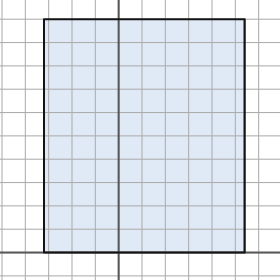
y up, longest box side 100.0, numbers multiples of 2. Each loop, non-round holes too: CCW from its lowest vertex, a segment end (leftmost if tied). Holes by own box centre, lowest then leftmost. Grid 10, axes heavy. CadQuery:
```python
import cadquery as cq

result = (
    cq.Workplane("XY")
    .moveTo(-32.0, 0.0)
    .lineTo(54.0, 0.0)
    .lineTo(54.0, 100.0)
    .lineTo(-32.0, 100.0)
    .close()
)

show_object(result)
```